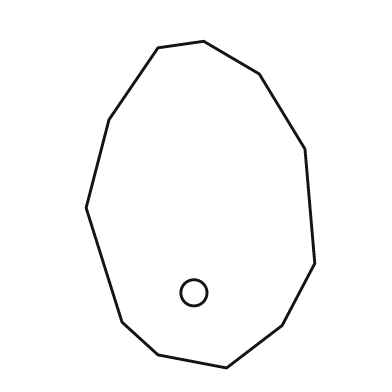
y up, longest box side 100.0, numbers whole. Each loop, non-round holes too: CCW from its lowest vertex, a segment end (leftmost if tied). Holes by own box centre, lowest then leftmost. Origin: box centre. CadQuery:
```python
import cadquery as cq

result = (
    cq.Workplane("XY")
    .moveTo(8.0, -50.0)
    .lineTo(25.0, -37.0)
    .lineTo(35.0, -18.0)
    .lineTo(32.0, 17.0)
    .lineTo(18.0, 40.0)
    .lineTo(1.0, 50.0)
    .lineTo(-13.0, 48.0)
    .lineTo(-28.0, 26.0)
    .lineTo(-35.0, -1.0)
    .lineTo(-24.0, -36.0)
    .lineTo(-13.0, -46.0)
    .close()
    .moveTo(-2.0, -27.0)
    .circle(4.0)
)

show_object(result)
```